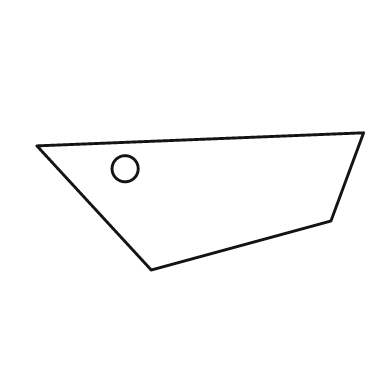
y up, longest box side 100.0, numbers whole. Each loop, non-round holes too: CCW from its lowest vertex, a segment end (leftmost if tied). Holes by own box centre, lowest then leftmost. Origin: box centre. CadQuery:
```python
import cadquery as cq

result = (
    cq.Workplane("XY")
    .moveTo(-15.0, -21.0)
    .lineTo(40.0, -6.0)
    .lineTo(50.0, 21.0)
    .lineTo(-50.0, 17.0)
    .close()
    .moveTo(-23.0, 10.0)
    .circle(4.0)
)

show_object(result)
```